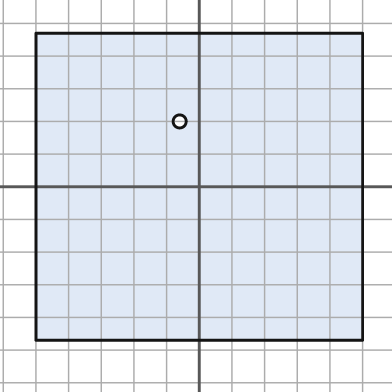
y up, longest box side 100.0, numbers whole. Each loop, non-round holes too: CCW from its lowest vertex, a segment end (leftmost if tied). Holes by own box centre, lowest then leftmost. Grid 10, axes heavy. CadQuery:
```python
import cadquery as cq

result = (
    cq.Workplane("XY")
    .moveTo(-50.0, -47.0)
    .lineTo(50.0, -47.0)
    .lineTo(50.0, 47.0)
    .lineTo(-50.0, 47.0)
    .close()
    .moveTo(-6.0, 20.0)
    .circle(2.0)
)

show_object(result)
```